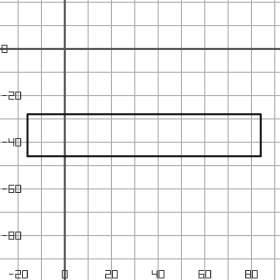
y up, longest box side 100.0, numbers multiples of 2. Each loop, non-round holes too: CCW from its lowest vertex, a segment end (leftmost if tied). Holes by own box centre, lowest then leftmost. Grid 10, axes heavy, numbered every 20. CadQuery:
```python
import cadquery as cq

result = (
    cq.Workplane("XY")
    .moveTo(-16.0, -46.0)
    .lineTo(84.0, -46.0)
    .lineTo(84.0, -28.0)
    .lineTo(-16.0, -28.0)
    .close()
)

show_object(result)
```